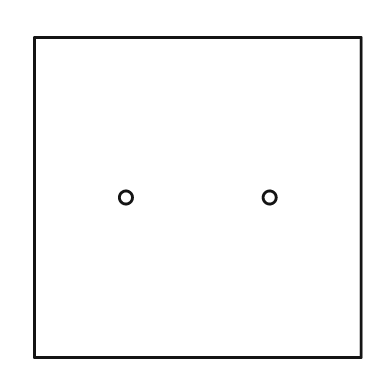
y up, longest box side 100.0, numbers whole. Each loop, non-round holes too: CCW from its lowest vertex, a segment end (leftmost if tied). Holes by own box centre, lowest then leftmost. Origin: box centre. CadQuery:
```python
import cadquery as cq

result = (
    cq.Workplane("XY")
    .moveTo(-50.0, -49.0)
    .lineTo(50.0, -49.0)
    .lineTo(50.0, 49.0)
    .lineTo(-50.0, 49.0)
    .close()
    .moveTo(-22.0, 0.0)
    .circle(2.0)
    .moveTo(22.0, 0.0)
    .circle(2.0)
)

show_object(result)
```